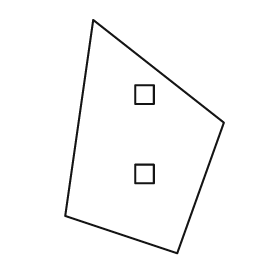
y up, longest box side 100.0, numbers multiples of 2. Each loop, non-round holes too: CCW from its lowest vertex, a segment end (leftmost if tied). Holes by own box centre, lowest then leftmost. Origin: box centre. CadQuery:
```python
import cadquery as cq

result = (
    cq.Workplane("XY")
    .moveTo(14.0, -50.0)
    .lineTo(34.0, 6.0)
    .lineTo(-22.0, 50.0)
    .lineTo(-34.0, -34.0)
    .close()
    .moveTo(-4.0, -20.0)
    .lineTo(4.0, -20.0)
    .lineTo(4.0, -12.0)
    .lineTo(-4.0, -12.0)
    .close()
    .moveTo(-4.0, 14.0)
    .lineTo(4.0, 14.0)
    .lineTo(4.0, 22.0)
    .lineTo(-4.0, 22.0)
    .close()
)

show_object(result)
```